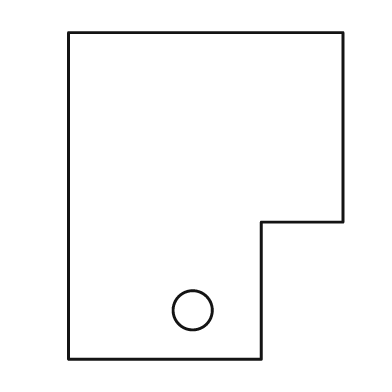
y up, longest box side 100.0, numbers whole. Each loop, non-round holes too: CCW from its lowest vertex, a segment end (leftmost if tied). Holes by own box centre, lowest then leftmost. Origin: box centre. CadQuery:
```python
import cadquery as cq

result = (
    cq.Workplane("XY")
    .moveTo(-42.0, -50.0)
    .lineTo(17.0, -50.0)
    .lineTo(17.0, -8.0)
    .lineTo(42.0, -8.0)
    .lineTo(42.0, 50.0)
    .lineTo(-42.0, 50.0)
    .close()
    .moveTo(-4.0, -35.0)
    .circle(6.0)
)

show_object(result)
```